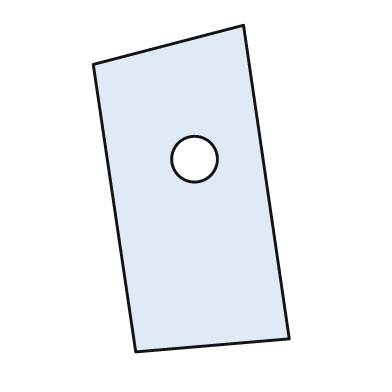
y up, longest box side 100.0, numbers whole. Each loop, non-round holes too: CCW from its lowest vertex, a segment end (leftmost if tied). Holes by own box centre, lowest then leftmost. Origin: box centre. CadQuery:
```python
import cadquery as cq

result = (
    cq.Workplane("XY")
    .moveTo(-17.0, -50.0)
    .lineTo(30.0, -46.0)
    .lineTo(16.0, 50.0)
    .lineTo(-30.0, 38.0)
    .close()
    .moveTo(1.0, 9.0)
    .circle(7.0)
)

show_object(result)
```